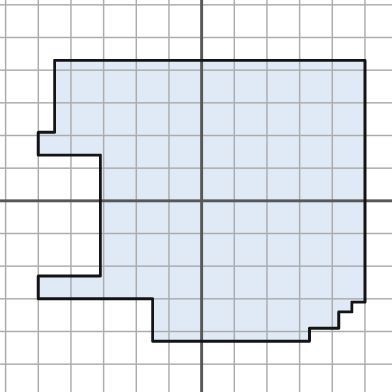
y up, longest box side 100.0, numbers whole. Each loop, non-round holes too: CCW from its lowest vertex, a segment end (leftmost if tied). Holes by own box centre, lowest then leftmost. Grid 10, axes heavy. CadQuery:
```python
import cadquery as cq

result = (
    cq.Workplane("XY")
    .moveTo(-15.0, -43.0)
    .lineTo(33.0, -43.0)
    .lineTo(33.0, -39.0)
    .lineTo(42.0, -39.0)
    .lineTo(42.0, -34.0)
    .lineTo(46.0, -34.0)
    .lineTo(46.0, -31.0)
    .lineTo(50.0, -31.0)
    .lineTo(50.0, 43.0)
    .lineTo(-45.0, 43.0)
    .lineTo(-45.0, 21.0)
    .lineTo(-50.0, 21.0)
    .lineTo(-50.0, 14.0)
    .lineTo(-31.0, 14.0)
    .lineTo(-31.0, -23.0)
    .lineTo(-50.0, -23.0)
    .lineTo(-50.0, -30.0)
    .lineTo(-15.0, -30.0)
    .close()
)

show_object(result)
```